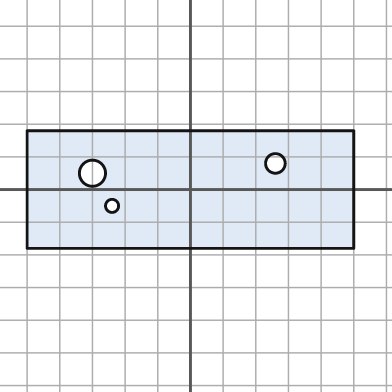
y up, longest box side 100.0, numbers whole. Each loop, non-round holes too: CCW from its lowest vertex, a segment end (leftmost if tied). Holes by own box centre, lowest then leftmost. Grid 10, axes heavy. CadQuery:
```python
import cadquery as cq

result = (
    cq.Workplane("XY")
    .moveTo(-50.0, -18.0)
    .lineTo(50.0, -18.0)
    .lineTo(50.0, 18.0)
    .lineTo(-50.0, 18.0)
    .close()
    .moveTo(-24.0, -5.0)
    .circle(2.0)
    .moveTo(-30.0, 5.0)
    .circle(4.0)
    .moveTo(26.0, 8.0)
    .circle(3.0)
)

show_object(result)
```